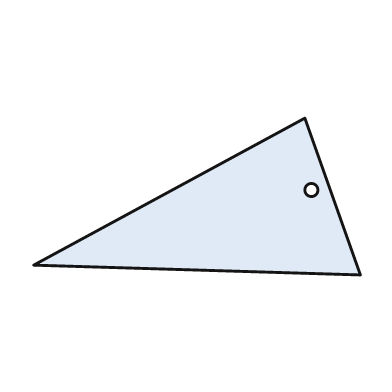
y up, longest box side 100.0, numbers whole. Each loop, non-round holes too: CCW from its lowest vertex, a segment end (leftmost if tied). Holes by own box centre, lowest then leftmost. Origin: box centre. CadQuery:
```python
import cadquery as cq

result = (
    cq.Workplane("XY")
    .moveTo(50.0, -24.0)
    .lineTo(33.0, 24.0)
    .lineTo(-50.0, -21.0)
    .close()
    .moveTo(35.0, 2.0)
    .circle(2.0)
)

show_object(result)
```